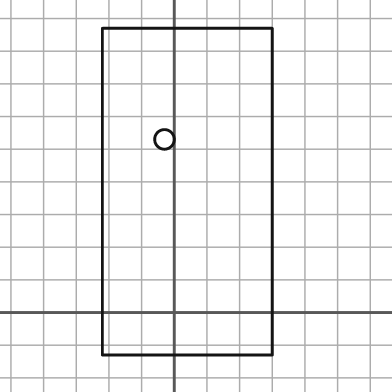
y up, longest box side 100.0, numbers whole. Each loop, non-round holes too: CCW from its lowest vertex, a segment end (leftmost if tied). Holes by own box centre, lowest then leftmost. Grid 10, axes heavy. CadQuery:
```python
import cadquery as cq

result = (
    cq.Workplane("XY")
    .moveTo(-22.0, -13.0)
    .lineTo(30.0, -13.0)
    .lineTo(30.0, 87.0)
    .lineTo(-22.0, 87.0)
    .close()
    .moveTo(-3.0, 53.0)
    .circle(3.0)
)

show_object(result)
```